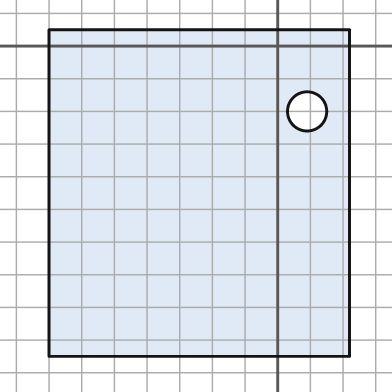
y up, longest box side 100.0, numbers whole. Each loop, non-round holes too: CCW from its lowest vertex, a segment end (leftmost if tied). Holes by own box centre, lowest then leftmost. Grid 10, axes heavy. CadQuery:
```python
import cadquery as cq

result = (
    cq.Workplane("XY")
    .moveTo(-70.0, -95.0)
    .lineTo(22.0, -95.0)
    .lineTo(22.0, 5.0)
    .lineTo(-70.0, 5.0)
    .close()
    .moveTo(9.0, -20.0)
    .circle(6.0)
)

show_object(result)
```